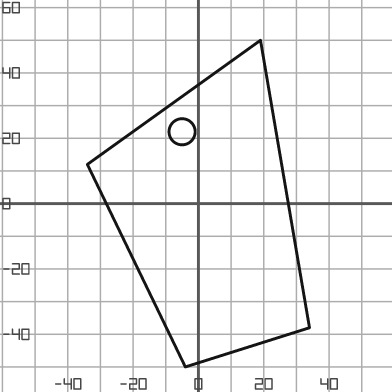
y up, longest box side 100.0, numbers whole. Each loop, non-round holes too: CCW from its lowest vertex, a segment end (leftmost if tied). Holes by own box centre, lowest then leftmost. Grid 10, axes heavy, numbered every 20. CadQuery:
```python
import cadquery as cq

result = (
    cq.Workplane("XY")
    .moveTo(-4.0, -50.0)
    .lineTo(34.0, -38.0)
    .lineTo(19.0, 50.0)
    .lineTo(-34.0, 12.0)
    .close()
    .moveTo(-5.0, 22.0)
    .circle(4.0)
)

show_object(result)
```